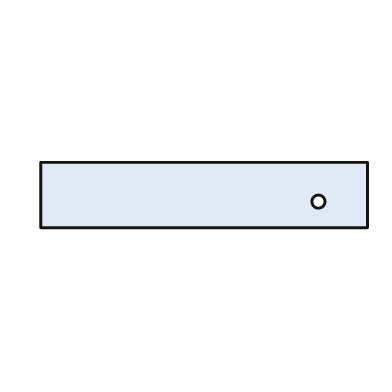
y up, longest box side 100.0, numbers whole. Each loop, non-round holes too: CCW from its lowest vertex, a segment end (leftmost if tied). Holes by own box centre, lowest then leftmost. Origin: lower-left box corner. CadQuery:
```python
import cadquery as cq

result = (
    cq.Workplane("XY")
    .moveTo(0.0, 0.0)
    .lineTo(100.0, 0.0)
    .lineTo(100.0, 20.0)
    .lineTo(0.0, 20.0)
    .close()
    .moveTo(85.0, 8.0)
    .circle(2.0)
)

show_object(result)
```